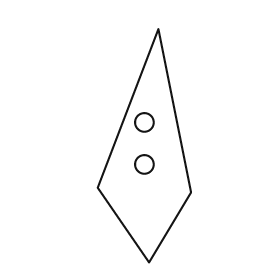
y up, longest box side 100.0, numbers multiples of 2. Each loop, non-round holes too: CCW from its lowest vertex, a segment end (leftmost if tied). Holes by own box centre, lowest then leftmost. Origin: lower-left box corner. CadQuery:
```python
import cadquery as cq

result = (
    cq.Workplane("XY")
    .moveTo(22.0, 0.0)
    .lineTo(40.0, 30.0)
    .lineTo(26.0, 100.0)
    .lineTo(0.0, 32.0)
    .close()
    .moveTo(20.0, 42.0)
    .circle(4.0)
    .moveTo(20.0, 60.0)
    .circle(4.0)
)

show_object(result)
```